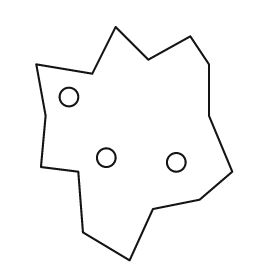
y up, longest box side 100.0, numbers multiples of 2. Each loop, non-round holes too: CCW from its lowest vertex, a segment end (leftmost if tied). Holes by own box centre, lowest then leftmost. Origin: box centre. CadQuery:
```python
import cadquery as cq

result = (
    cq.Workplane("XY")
    .moveTo(-2.0, -50.0)
    .lineTo(8.0, -28.0)
    .lineTo(28.0, -24.0)
    .lineTo(42.0, -12.0)
    .lineTo(32.0, 12.0)
    .lineTo(32.0, 34.0)
    .lineTo(24.0, 46.0)
    .lineTo(6.0, 36.0)
    .lineTo(-8.0, 50.0)
    .lineTo(-18.0, 30.0)
    .lineTo(-42.0, 34.0)
    .lineTo(-38.0, 12.0)
    .lineTo(-40.0, -10.0)
    .lineTo(-24.0, -12.0)
    .lineTo(-22.0, -38.0)
    .close()
    .moveTo(18.0, -8.0)
    .circle(4.0)
    .moveTo(-12.0, -6.0)
    .circle(4.0)
    .moveTo(-28.0, 20.0)
    .circle(4.0)
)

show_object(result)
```